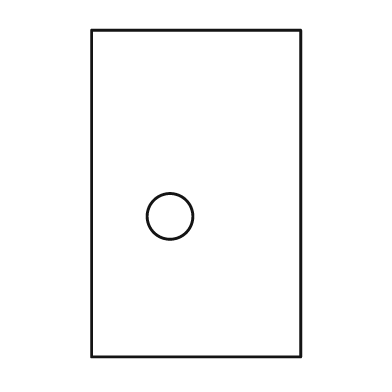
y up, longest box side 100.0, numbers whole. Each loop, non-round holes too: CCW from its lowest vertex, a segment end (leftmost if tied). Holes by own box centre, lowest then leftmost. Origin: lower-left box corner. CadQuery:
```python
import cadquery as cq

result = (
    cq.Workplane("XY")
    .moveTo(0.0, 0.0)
    .lineTo(64.0, 0.0)
    .lineTo(64.0, 100.0)
    .lineTo(0.0, 100.0)
    .close()
    .moveTo(24.0, 43.0)
    .circle(7.0)
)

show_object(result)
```